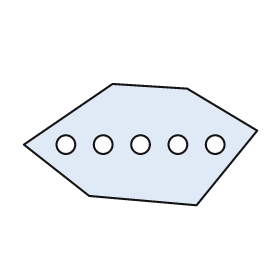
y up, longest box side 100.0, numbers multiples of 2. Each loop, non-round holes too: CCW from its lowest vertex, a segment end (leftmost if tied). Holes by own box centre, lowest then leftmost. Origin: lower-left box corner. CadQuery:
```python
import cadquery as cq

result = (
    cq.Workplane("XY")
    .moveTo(74.0, 0.0)
    .lineTo(100.0, 32.0)
    .lineTo(70.0, 50.0)
    .lineTo(38.0, 52.0)
    .lineTo(0.0, 26.0)
    .lineTo(28.0, 4.0)
    .close()
    .moveTo(18.0, 26.0)
    .circle(4.0)
    .moveTo(34.0, 26.0)
    .circle(4.0)
    .moveTo(50.0, 26.0)
    .circle(4.0)
    .moveTo(66.0, 26.0)
    .circle(4.0)
    .moveTo(82.0, 26.0)
    .circle(4.0)
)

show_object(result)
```